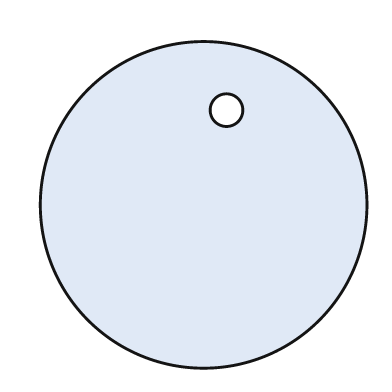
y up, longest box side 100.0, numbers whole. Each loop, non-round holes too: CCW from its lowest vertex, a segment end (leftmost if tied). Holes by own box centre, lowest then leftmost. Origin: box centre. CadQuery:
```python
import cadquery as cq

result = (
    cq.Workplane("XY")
    .moveTo(0.0, 0.0)
    .circle(50.0)
    .moveTo(7.0, 29.0)
    .circle(5.0)
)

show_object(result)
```